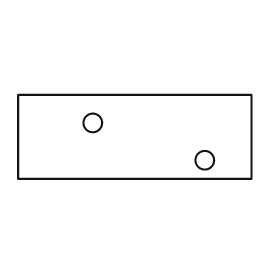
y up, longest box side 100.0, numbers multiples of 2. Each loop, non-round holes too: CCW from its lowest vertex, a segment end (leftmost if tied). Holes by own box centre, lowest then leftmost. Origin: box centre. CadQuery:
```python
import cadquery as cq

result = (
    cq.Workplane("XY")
    .moveTo(-50.0, -18.0)
    .lineTo(50.0, -18.0)
    .lineTo(50.0, 18.0)
    .lineTo(-50.0, 18.0)
    .close()
    .moveTo(30.0, -10.0)
    .circle(4.0)
    .moveTo(-18.0, 6.0)
    .circle(4.0)
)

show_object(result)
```